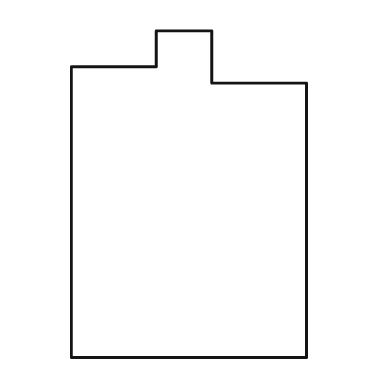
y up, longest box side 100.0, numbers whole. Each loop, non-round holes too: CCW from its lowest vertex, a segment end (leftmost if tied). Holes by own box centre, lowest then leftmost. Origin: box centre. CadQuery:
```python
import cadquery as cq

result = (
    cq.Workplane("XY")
    .moveTo(-36.0, -50.0)
    .lineTo(36.0, -50.0)
    .lineTo(36.0, 34.0)
    .lineTo(7.0, 34.0)
    .lineTo(7.0, 50.0)
    .lineTo(-10.0, 50.0)
    .lineTo(-10.0, 39.0)
    .lineTo(-36.0, 39.0)
    .close()
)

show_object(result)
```